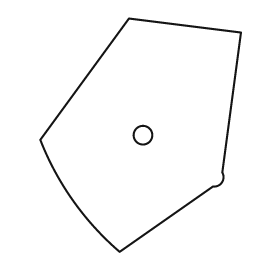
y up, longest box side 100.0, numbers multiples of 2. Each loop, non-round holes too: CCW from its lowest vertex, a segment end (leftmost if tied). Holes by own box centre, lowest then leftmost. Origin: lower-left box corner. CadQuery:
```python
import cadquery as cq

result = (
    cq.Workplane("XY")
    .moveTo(34.0, 0.0)
    .lineTo(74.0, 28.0)
    .threePointArc((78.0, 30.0), (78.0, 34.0))
    .lineTo(86.0, 94.0)
    .lineTo(38.0, 100.0)
    .lineTo(0.0, 48.0)
    .threePointArc((14.0, 22.0), (34.0, 0.0))
    .close()
    .moveTo(44.0, 50.0)
    .circle(4.0)
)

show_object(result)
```